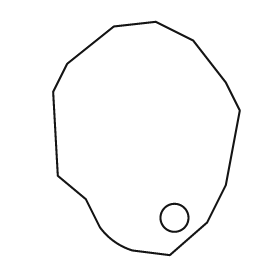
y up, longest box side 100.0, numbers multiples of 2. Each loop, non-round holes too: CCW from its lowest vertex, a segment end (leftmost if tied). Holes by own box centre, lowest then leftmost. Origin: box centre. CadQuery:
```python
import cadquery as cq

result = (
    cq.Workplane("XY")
    .moveTo(10.0, -50.0)
    .lineTo(26.0, -36.0)
    .lineTo(34.0, -20.0)
    .lineTo(40.0, 12.0)
    .lineTo(34.0, 24.0)
    .lineTo(20.0, 42.0)
    .lineTo(4.0, 50.0)
    .lineTo(-14.0, 48.0)
    .lineTo(-34.0, 32.0)
    .lineTo(-40.0, 20.0)
    .lineTo(-38.0, -16.0)
    .lineTo(-26.0, -26.0)
    .lineTo(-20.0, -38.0)
    .threePointArc((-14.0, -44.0), (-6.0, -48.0))
    .close()
    .moveTo(12.0, -34.0)
    .circle(6.0)
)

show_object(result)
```